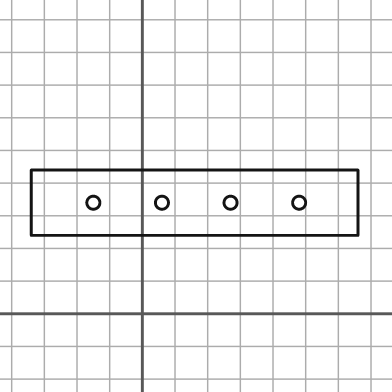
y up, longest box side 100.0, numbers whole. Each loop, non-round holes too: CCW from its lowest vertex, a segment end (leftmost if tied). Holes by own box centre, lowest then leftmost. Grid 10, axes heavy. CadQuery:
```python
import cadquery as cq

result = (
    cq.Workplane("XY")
    .moveTo(-34.0, 24.0)
    .lineTo(66.0, 24.0)
    .lineTo(66.0, 44.0)
    .lineTo(-34.0, 44.0)
    .close()
    .moveTo(-15.0, 34.0)
    .circle(2.0)
    .moveTo(6.0, 34.0)
    .circle(2.0)
    .moveTo(27.0, 34.0)
    .circle(2.0)
    .moveTo(48.0, 34.0)
    .circle(2.0)
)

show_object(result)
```